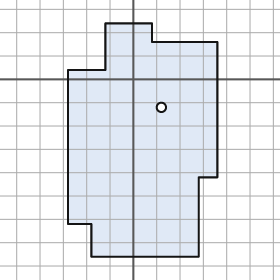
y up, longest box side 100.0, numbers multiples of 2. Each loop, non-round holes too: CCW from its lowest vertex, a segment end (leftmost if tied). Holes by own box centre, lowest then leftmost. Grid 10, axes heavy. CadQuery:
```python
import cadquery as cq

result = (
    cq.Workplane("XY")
    .moveTo(-18.0, -76.0)
    .lineTo(28.0, -76.0)
    .lineTo(28.0, -42.0)
    .lineTo(36.0, -42.0)
    .lineTo(36.0, 16.0)
    .lineTo(8.0, 16.0)
    .lineTo(8.0, 24.0)
    .lineTo(-12.0, 24.0)
    .lineTo(-12.0, 4.0)
    .lineTo(-28.0, 4.0)
    .lineTo(-28.0, -62.0)
    .lineTo(-18.0, -62.0)
    .close()
    .moveTo(12.0, -12.0)
    .circle(2.0)
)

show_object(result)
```